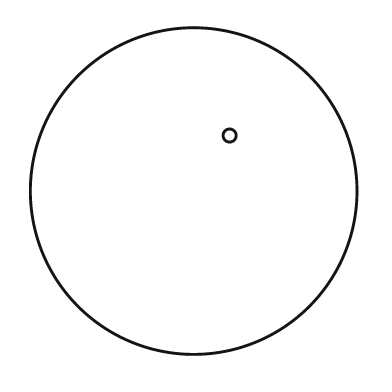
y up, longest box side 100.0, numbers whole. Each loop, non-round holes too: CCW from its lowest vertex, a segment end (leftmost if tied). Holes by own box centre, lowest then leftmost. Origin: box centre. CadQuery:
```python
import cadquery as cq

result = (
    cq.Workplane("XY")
    .moveTo(0.0, 0.0)
    .circle(50.0)
    .moveTo(11.0, 17.0)
    .circle(2.0)
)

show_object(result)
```